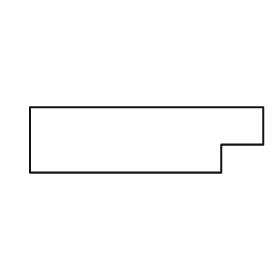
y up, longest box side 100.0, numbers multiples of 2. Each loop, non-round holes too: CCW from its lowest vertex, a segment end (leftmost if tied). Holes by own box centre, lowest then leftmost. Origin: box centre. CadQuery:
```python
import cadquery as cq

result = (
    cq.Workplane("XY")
    .moveTo(-50.0, -14.0)
    .lineTo(32.0, -14.0)
    .lineTo(32.0, -2.0)
    .lineTo(50.0, -2.0)
    .lineTo(50.0, 14.0)
    .lineTo(-50.0, 14.0)
    .close()
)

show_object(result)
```